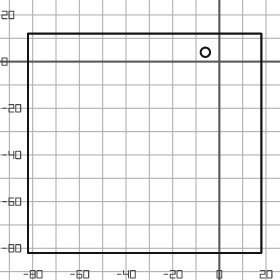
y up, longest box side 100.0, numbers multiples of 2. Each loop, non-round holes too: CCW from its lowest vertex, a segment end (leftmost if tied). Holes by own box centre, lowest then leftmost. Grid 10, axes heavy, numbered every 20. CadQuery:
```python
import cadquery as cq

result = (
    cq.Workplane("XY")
    .moveTo(-82.0, -82.0)
    .lineTo(18.0, -82.0)
    .lineTo(18.0, 12.0)
    .lineTo(-82.0, 12.0)
    .close()
    .moveTo(-6.0, 4.0)
    .circle(2.0)
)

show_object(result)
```